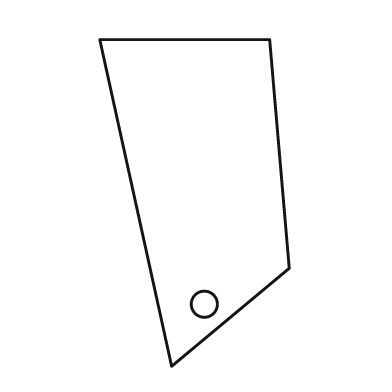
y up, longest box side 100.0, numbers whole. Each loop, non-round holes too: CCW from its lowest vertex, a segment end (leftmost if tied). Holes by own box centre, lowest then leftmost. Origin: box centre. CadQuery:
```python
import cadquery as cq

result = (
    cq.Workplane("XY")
    .moveTo(-7.0, -50.0)
    .lineTo(29.0, -20.0)
    .lineTo(23.0, 50.0)
    .lineTo(-29.0, 50.0)
    .close()
    .moveTo(3.0, -31.0)
    .circle(4.0)
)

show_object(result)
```